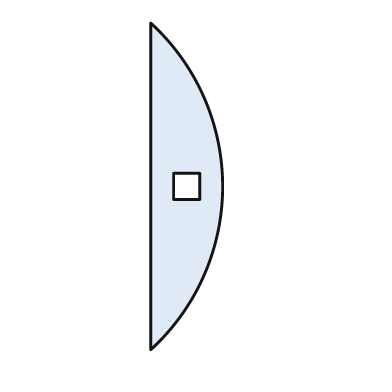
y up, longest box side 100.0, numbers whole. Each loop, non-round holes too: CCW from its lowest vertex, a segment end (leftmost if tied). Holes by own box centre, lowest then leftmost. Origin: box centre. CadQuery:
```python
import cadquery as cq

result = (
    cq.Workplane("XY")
    .moveTo(-11.0, -50.0)
    .threePointArc((11.0, 0.0), (-11.0, 50.0))
    .close()
    .moveTo(-4.0, -4.0)
    .lineTo(4.0, -4.0)
    .lineTo(4.0, 4.0)
    .lineTo(-4.0, 4.0)
    .close()
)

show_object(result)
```